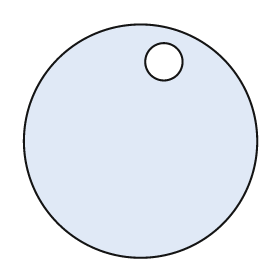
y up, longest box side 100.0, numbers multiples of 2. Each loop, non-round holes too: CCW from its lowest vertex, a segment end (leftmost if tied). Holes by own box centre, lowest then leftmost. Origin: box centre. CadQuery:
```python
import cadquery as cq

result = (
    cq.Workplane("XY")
    .moveTo(0.0, 0.0)
    .circle(50.0)
    .moveTo(10.0, 34.0)
    .circle(8.0)
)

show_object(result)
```